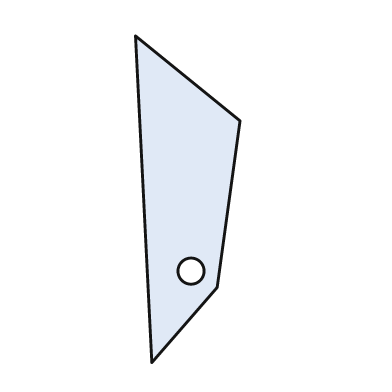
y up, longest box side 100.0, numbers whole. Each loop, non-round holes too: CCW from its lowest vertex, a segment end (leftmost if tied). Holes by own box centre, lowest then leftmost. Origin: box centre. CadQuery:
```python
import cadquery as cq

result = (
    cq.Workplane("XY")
    .moveTo(-11.0, -50.0)
    .lineTo(9.0, -27.0)
    .lineTo(16.0, 24.0)
    .lineTo(-16.0, 50.0)
    .close()
    .moveTo(1.0, -22.0)
    .circle(4.0)
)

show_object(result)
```